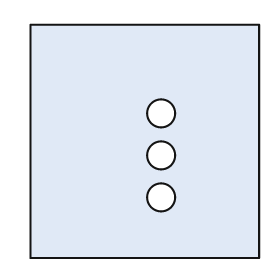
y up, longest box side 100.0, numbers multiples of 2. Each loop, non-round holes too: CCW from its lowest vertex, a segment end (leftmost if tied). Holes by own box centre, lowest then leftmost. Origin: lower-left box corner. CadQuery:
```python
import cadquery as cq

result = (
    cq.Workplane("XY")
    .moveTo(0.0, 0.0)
    .lineTo(98.0, 0.0)
    .lineTo(98.0, 100.0)
    .lineTo(0.0, 100.0)
    .close()
    .moveTo(56.0, 26.0)
    .circle(6.0)
    .moveTo(56.0, 44.0)
    .circle(6.0)
    .moveTo(56.0, 62.0)
    .circle(6.0)
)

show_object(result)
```